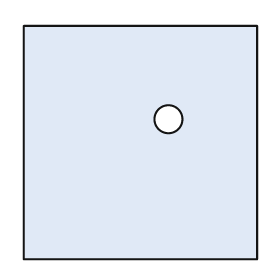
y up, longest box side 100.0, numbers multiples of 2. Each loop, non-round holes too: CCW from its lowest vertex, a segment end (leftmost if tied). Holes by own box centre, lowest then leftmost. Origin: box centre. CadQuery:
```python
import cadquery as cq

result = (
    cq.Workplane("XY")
    .moveTo(-50.0, -50.0)
    .lineTo(50.0, -50.0)
    .lineTo(50.0, 50.0)
    .lineTo(-50.0, 50.0)
    .close()
    .moveTo(12.0, 10.0)
    .circle(6.0)
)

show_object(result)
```